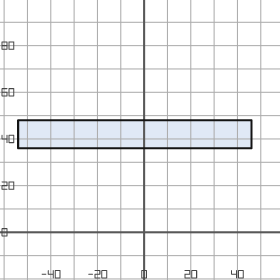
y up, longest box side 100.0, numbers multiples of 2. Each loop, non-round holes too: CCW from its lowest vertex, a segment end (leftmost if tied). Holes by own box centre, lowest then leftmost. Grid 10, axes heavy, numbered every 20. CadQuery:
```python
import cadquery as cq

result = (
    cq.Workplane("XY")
    .moveTo(-54.0, 36.0)
    .lineTo(46.0, 36.0)
    .lineTo(46.0, 48.0)
    .lineTo(-54.0, 48.0)
    .close()
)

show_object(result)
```